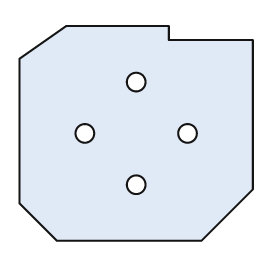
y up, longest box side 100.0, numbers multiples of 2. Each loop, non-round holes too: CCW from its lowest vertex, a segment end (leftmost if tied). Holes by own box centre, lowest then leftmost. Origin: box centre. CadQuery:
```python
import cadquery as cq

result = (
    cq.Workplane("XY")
    .moveTo(-34.0, -46.0)
    .lineTo(28.0, -46.0)
    .lineTo(50.0, -24.0)
    .lineTo(50.0, 40.0)
    .lineTo(14.0, 40.0)
    .lineTo(14.0, 46.0)
    .lineTo(-30.0, 46.0)
    .lineTo(-50.0, 32.0)
    .lineTo(-50.0, -30.0)
    .close()
    .moveTo(0.0, -22.0)
    .circle(4.0)
    .moveTo(-22.0, 0.0)
    .circle(4.0)
    .moveTo(22.0, 0.0)
    .circle(4.0)
    .moveTo(0.0, 22.0)
    .circle(4.0)
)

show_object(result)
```